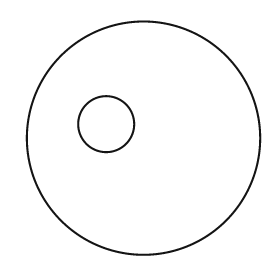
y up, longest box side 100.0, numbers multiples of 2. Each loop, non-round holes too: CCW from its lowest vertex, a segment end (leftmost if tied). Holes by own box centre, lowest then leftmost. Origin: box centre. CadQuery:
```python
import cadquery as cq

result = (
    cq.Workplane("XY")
    .moveTo(0.0, 0.0)
    .circle(50.0)
    .moveTo(-16.0, 6.0)
    .circle(12.0)
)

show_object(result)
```